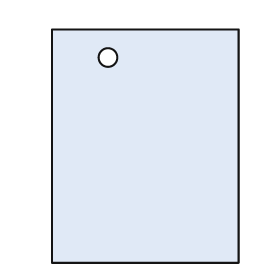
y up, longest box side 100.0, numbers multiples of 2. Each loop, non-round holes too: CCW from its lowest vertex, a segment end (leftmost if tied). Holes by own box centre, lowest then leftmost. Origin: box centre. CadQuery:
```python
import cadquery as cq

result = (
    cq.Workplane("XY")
    .moveTo(-40.0, -50.0)
    .lineTo(40.0, -50.0)
    .lineTo(40.0, 50.0)
    .lineTo(-40.0, 50.0)
    .close()
    .moveTo(-16.0, 38.0)
    .circle(4.0)
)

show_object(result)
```